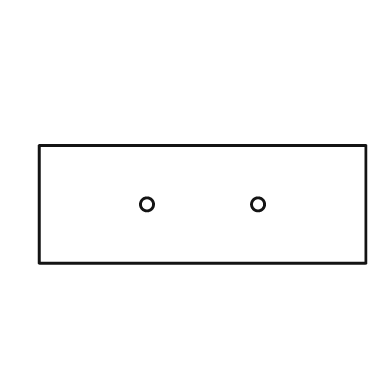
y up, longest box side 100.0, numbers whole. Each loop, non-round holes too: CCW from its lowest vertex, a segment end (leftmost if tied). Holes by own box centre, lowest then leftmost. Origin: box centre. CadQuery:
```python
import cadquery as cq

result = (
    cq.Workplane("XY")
    .moveTo(-50.0, -18.0)
    .lineTo(50.0, -18.0)
    .lineTo(50.0, 18.0)
    .lineTo(-50.0, 18.0)
    .close()
    .moveTo(-17.0, 0.0)
    .circle(2.0)
    .moveTo(17.0, 0.0)
    .circle(2.0)
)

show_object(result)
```